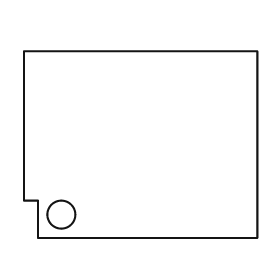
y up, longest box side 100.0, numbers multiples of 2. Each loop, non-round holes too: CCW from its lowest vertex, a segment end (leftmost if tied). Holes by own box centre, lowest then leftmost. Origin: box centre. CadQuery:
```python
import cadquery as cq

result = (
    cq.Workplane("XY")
    .moveTo(-44.0, -40.0)
    .lineTo(50.0, -40.0)
    .lineTo(50.0, 40.0)
    .lineTo(-50.0, 40.0)
    .lineTo(-50.0, -24.0)
    .lineTo(-44.0, -24.0)
    .close()
    .moveTo(-34.0, -30.0)
    .circle(6.0)
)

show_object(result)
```